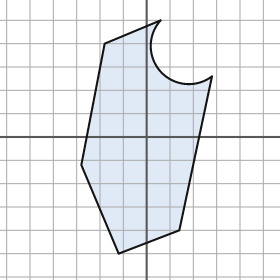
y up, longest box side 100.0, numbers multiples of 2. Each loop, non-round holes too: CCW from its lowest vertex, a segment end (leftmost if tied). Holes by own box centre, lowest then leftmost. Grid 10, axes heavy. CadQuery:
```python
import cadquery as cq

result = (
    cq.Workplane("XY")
    .moveTo(-12.0, -50.0)
    .lineTo(14.0, -40.0)
    .lineTo(28.0, 26.0)
    .threePointArc((6.0, 28.0), (6.0, 50.0))
    .lineTo(-18.0, 40.0)
    .lineTo(-28.0, -12.0)
    .close()
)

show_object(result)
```